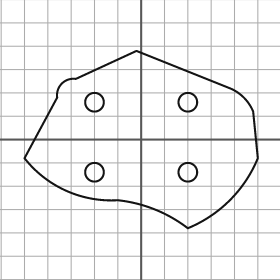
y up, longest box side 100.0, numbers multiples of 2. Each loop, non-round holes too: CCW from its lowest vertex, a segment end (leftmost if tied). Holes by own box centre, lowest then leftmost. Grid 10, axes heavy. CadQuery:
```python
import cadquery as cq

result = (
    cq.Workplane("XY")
    .moveTo(20.0, -38.0)
    .threePointArc((38.0, -26.0), (50.0, -8.0))
    .lineTo(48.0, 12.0)
    .threePointArc((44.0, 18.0), (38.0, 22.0))
    .lineTo(-2.0, 38.0)
    .lineTo(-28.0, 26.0)
    .threePointArc((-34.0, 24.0), (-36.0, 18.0))
    .lineTo(-50.0, -8.0)
    .threePointArc((-32.0, -22.0), (-10.0, -26.0))
    .threePointArc((6.0, -30.0), (20.0, -38.0))
    .close()
    .moveTo(-20.0, -14.0)
    .circle(4.0)
    .moveTo(20.0, -14.0)
    .circle(4.0)
    .moveTo(-20.0, 16.0)
    .circle(4.0)
    .moveTo(20.0, 16.0)
    .circle(4.0)
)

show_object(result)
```